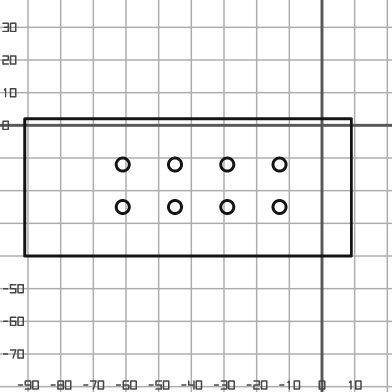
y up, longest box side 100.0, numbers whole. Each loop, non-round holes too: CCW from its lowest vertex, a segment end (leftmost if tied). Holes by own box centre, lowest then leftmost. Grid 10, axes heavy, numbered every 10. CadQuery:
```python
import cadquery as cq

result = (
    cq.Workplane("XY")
    .moveTo(-91.0, -40.0)
    .lineTo(9.0, -40.0)
    .lineTo(9.0, 2.0)
    .lineTo(-91.0, 2.0)
    .close()
    .moveTo(-61.0, -25.0)
    .circle(2.0)
    .moveTo(-45.0, -25.0)
    .circle(2.0)
    .moveTo(-29.0, -25.0)
    .circle(2.0)
    .moveTo(-13.0, -25.0)
    .circle(2.0)
    .moveTo(-61.0, -12.0)
    .circle(2.0)
    .moveTo(-45.0, -12.0)
    .circle(2.0)
    .moveTo(-29.0, -12.0)
    .circle(2.0)
    .moveTo(-13.0, -12.0)
    .circle(2.0)
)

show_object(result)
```